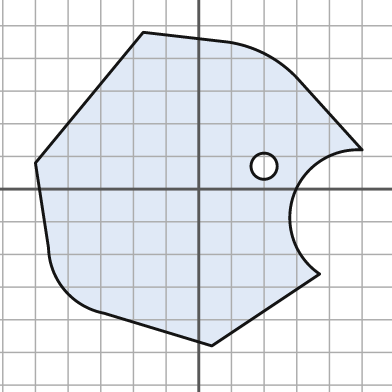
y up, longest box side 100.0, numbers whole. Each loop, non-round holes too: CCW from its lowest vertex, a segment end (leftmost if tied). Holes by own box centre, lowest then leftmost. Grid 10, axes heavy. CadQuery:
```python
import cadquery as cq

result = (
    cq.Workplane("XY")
    .moveTo(4.0, -48.0)
    .lineTo(37.0, -26.0)
    .threePointArc((29.0, -2.0), (50.0, 12.0))
    .lineTo(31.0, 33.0)
    .threePointArc((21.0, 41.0), (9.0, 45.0))
    .lineTo(-17.0, 48.0)
    .lineTo(-50.0, 8.0)
    .lineTo(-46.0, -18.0)
    .threePointArc((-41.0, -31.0), (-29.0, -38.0))
    .close()
    .moveTo(20.0, 7.0)
    .circle(4.0)
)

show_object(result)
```